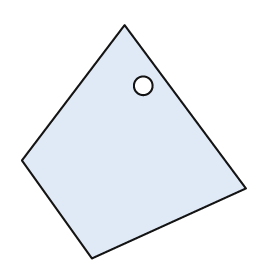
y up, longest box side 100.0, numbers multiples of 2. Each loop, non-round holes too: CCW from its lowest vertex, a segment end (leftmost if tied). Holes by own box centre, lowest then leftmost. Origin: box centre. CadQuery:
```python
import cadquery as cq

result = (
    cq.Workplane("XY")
    .moveTo(-18.0, -50.0)
    .lineTo(48.0, -20.0)
    .lineTo(-4.0, 50.0)
    .lineTo(-48.0, -8.0)
    .close()
    .moveTo(4.0, 24.0)
    .circle(4.0)
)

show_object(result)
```